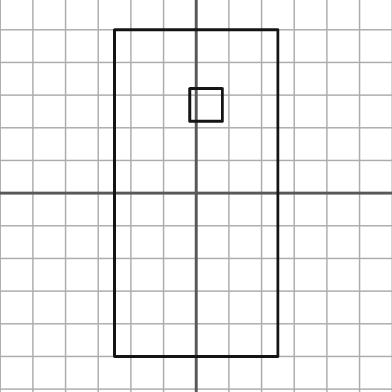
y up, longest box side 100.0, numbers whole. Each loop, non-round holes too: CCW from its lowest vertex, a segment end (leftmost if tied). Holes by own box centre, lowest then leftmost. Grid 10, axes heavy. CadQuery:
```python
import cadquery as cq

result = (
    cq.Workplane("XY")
    .moveTo(-25.0, -50.0)
    .lineTo(25.0, -50.0)
    .lineTo(25.0, 50.0)
    .lineTo(-25.0, 50.0)
    .close()
    .moveTo(-2.0, 22.0)
    .lineTo(8.0, 22.0)
    .lineTo(8.0, 32.0)
    .lineTo(-2.0, 32.0)
    .close()
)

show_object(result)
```